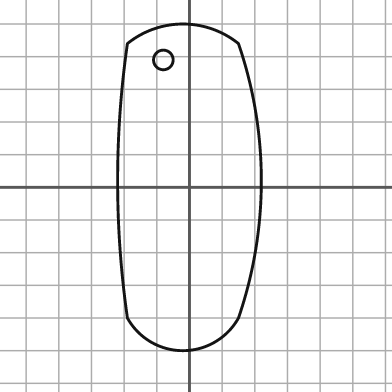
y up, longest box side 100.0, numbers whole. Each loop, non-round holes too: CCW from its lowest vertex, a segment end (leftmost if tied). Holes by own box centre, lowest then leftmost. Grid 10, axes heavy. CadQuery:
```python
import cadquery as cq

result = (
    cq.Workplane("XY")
    .moveTo(-19.0, -40.0)
    .threePointArc((-2.0, -50.0), (15.0, -40.0))
    .threePointArc((22.0, 2.0), (15.0, 44.0))
    .threePointArc((-2.0, 50.0), (-19.0, 44.0))
    .threePointArc((-22.0, 2.0), (-19.0, -40.0))
    .close()
    .moveTo(-8.0, 39.0)
    .circle(3.0)
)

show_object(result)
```